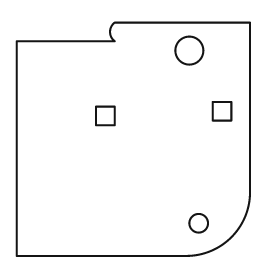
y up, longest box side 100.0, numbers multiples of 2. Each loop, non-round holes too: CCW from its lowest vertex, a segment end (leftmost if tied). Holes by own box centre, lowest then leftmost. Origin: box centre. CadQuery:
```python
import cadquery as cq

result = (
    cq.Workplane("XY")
    .moveTo(-50.0, -50.0)
    .lineTo(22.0, -50.0)
    .threePointArc((42.0, -42.0), (50.0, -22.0))
    .lineTo(50.0, 50.0)
    .lineTo(-8.0, 50.0)
    .threePointArc((-10.0, 46.0), (-8.0, 42.0))
    .lineTo(-50.0, 42.0)
    .close()
    .moveTo(28.0, -36.0)
    .circle(4.0)
    .moveTo(-16.0, 6.0)
    .lineTo(-8.0, 6.0)
    .lineTo(-8.0, 14.0)
    .lineTo(-16.0, 14.0)
    .close()
    .moveTo(34.0, 8.0)
    .lineTo(42.0, 8.0)
    .lineTo(42.0, 16.0)
    .lineTo(34.0, 16.0)
    .close()
    .moveTo(24.0, 38.0)
    .circle(6.0)
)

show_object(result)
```